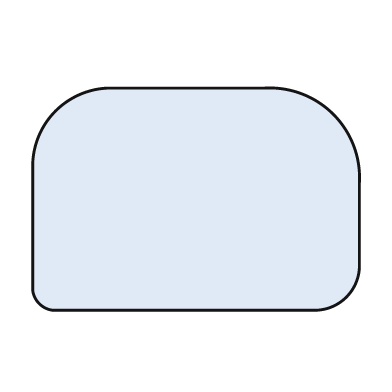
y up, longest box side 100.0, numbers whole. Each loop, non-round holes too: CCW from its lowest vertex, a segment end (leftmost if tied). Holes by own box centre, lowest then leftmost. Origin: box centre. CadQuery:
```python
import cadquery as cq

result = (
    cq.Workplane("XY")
    .moveTo(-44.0, -34.0)
    .lineTo(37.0, -34.0)
    .threePointArc((46.0, -30.0), (50.0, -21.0))
    .lineTo(50.0, 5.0)
    .threePointArc((42.0, 26.0), (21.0, 34.0))
    .lineTo(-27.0, 34.0)
    .threePointArc((-43.0, 27.0), (-50.0, 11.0))
    .lineTo(-50.0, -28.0)
    .threePointArc((-48.0, -32.0), (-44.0, -34.0))
    .close()
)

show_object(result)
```